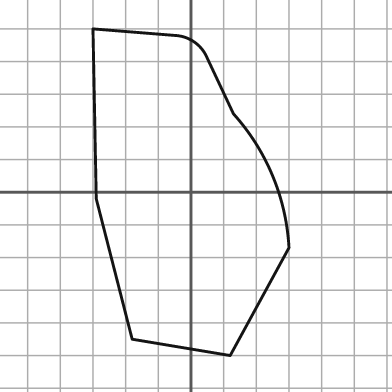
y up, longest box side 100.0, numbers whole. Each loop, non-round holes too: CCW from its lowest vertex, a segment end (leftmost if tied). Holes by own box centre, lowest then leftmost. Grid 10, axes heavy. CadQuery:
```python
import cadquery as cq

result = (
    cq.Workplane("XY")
    .moveTo(12.0, -50.0)
    .lineTo(30.0, -17.0)
    .threePointArc((25.0, 5.0), (13.0, 24.0))
    .lineTo(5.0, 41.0)
    .threePointArc((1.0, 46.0), (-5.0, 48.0))
    .lineTo(-30.0, 50.0)
    .lineTo(-29.0, -2.0)
    .lineTo(-18.0, -45.0)
    .close()
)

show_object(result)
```